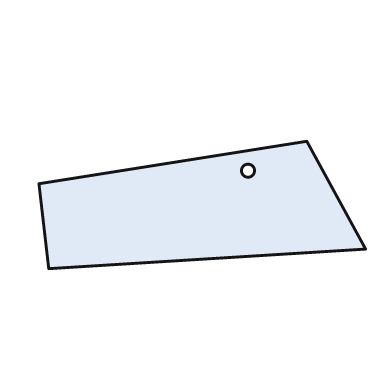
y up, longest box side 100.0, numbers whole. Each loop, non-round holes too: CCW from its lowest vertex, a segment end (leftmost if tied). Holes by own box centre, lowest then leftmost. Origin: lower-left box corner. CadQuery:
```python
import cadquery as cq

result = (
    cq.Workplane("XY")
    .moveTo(3.0, 0.0)
    .lineTo(100.0, 6.0)
    .lineTo(82.0, 39.0)
    .lineTo(0.0, 26.0)
    .close()
    .moveTo(64.0, 30.0)
    .circle(2.0)
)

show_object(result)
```